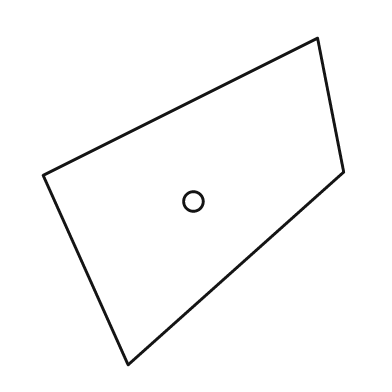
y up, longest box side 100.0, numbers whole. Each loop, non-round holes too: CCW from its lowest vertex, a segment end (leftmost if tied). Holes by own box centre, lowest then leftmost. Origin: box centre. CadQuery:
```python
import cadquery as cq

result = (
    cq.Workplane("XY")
    .moveTo(-20.0, -50.0)
    .lineTo(46.0, 9.0)
    .lineTo(38.0, 50.0)
    .lineTo(-46.0, 8.0)
    .close()
    .moveTo(0.0, 0.0)
    .circle(3.0)
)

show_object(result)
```